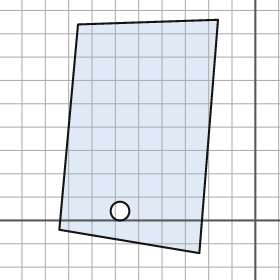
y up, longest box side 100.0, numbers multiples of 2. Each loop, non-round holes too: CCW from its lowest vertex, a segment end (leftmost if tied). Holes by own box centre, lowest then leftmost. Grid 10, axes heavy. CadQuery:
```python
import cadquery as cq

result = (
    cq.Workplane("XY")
    .moveTo(-24.0, -14.0)
    .lineTo(-16.0, 86.0)
    .lineTo(-76.0, 84.0)
    .lineTo(-84.0, -4.0)
    .close()
    .moveTo(-58.0, 4.0)
    .circle(4.0)
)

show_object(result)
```